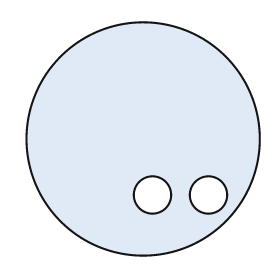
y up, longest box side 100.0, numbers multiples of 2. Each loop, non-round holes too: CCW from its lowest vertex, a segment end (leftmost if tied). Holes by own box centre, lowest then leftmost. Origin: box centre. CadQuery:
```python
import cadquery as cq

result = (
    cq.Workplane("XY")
    .moveTo(0.0, 0.0)
    .circle(50.0)
    .moveTo(4.0, -24.0)
    .circle(8.0)
    .moveTo(28.0, -24.0)
    .circle(8.0)
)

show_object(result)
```